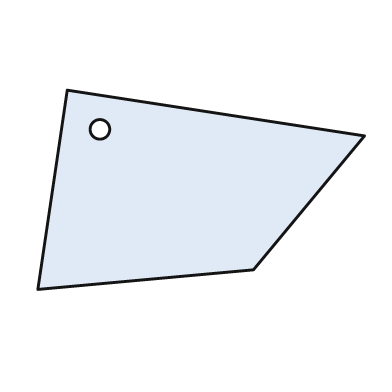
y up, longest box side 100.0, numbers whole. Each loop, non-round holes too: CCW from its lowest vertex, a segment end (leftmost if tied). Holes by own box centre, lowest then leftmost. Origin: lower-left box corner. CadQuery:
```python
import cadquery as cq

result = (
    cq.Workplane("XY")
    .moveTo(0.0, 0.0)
    .lineTo(66.0, 6.0)
    .lineTo(100.0, 47.0)
    .lineTo(9.0, 61.0)
    .close()
    .moveTo(19.0, 49.0)
    .circle(3.0)
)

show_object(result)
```